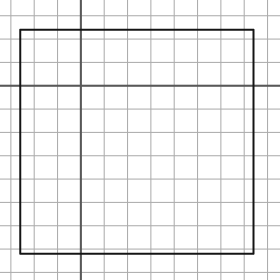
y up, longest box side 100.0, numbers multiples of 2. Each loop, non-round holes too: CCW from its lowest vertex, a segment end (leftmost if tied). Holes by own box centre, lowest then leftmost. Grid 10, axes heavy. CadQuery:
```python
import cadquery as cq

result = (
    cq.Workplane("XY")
    .moveTo(-26.0, -72.0)
    .lineTo(74.0, -72.0)
    .lineTo(74.0, 24.0)
    .lineTo(-26.0, 24.0)
    .close()
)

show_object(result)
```